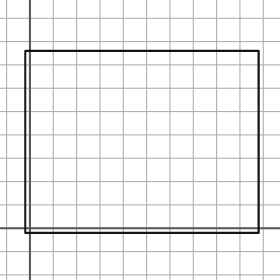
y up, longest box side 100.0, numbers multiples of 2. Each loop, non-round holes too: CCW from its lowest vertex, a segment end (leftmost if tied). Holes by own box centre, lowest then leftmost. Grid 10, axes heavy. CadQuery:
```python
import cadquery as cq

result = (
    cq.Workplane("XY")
    .moveTo(-2.0, -2.0)
    .lineTo(98.0, -2.0)
    .lineTo(98.0, 76.0)
    .lineTo(-2.0, 76.0)
    .close()
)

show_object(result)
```